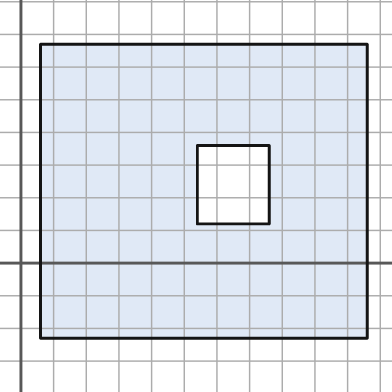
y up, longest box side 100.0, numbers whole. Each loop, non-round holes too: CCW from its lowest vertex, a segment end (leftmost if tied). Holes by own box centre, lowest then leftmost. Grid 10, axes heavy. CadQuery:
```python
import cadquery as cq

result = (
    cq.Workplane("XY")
    .moveTo(6.0, -23.0)
    .lineTo(106.0, -23.0)
    .lineTo(106.0, 67.0)
    .lineTo(6.0, 67.0)
    .close()
    .moveTo(54.0, 12.0)
    .lineTo(76.0, 12.0)
    .lineTo(76.0, 36.0)
    .lineTo(54.0, 36.0)
    .close()
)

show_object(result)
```